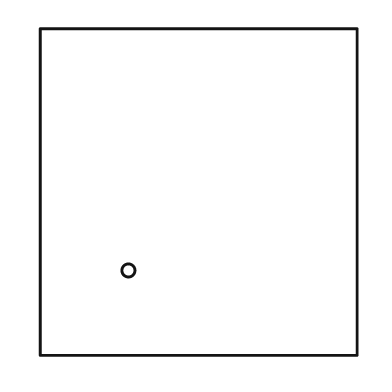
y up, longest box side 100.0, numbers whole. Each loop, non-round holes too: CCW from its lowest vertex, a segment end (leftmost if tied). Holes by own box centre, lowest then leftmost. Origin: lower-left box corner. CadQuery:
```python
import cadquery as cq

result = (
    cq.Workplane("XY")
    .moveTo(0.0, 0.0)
    .lineTo(97.0, 0.0)
    .lineTo(97.0, 100.0)
    .lineTo(0.0, 100.0)
    .close()
    .moveTo(27.0, 26.0)
    .circle(2.0)
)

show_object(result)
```